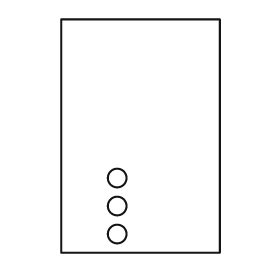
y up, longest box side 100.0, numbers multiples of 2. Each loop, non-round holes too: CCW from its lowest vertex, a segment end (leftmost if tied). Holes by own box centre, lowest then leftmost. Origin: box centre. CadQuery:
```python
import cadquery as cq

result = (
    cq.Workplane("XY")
    .moveTo(-34.0, -50.0)
    .lineTo(34.0, -50.0)
    .lineTo(34.0, 50.0)
    .lineTo(-34.0, 50.0)
    .close()
    .moveTo(-10.0, -42.0)
    .circle(4.0)
    .moveTo(-10.0, -30.0)
    .circle(4.0)
    .moveTo(-10.0, -18.0)
    .circle(4.0)
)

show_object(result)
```